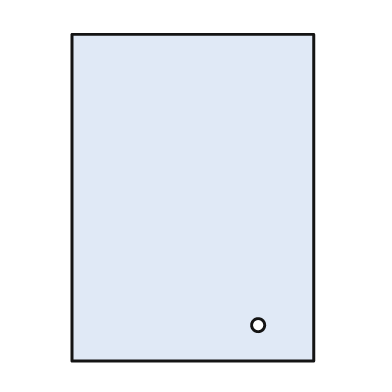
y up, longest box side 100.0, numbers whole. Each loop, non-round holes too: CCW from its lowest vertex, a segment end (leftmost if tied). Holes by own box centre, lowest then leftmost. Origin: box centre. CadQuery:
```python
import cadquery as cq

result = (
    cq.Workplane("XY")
    .moveTo(-37.0, -50.0)
    .lineTo(37.0, -50.0)
    .lineTo(37.0, 50.0)
    .lineTo(-37.0, 50.0)
    .close()
    .moveTo(20.0, -39.0)
    .circle(2.0)
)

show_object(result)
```